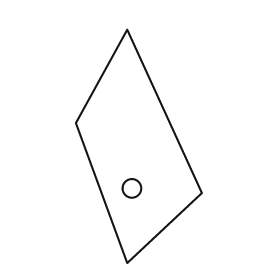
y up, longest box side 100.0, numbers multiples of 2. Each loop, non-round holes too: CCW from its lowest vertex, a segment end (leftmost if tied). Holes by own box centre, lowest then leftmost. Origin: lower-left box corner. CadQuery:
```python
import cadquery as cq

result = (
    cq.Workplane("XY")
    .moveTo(22.0, 0.0)
    .lineTo(54.0, 30.0)
    .lineTo(22.0, 100.0)
    .lineTo(0.0, 60.0)
    .close()
    .moveTo(24.0, 32.0)
    .circle(4.0)
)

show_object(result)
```